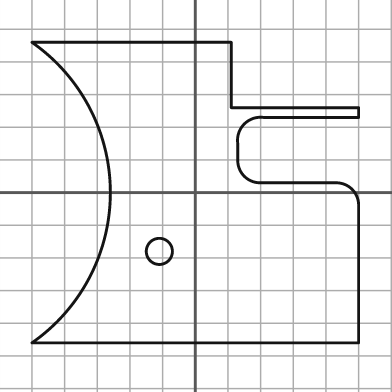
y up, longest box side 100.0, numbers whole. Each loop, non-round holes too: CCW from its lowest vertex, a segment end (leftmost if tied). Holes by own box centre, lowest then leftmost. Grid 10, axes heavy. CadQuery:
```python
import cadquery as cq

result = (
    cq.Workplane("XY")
    .moveTo(-50.0, -46.0)
    .lineTo(50.0, -46.0)
    .lineTo(50.0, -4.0)
    .threePointArc((48.0, 1.0), (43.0, 3.0))
    .lineTo(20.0, 3.0)
    .threePointArc((15.0, 5.0), (13.0, 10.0))
    .lineTo(13.0, 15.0)
    .threePointArc((15.0, 21.0), (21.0, 23.0))
    .lineTo(50.0, 23.0)
    .lineTo(50.0, 26.0)
    .lineTo(11.0, 26.0)
    .lineTo(11.0, 46.0)
    .lineTo(-50.0, 46.0)
    .threePointArc((-26.0, 0.0), (-50.0, -46.0))
    .close()
    .moveTo(-11.0, -18.0)
    .circle(4.0)
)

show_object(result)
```